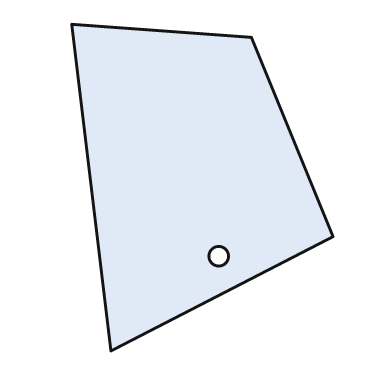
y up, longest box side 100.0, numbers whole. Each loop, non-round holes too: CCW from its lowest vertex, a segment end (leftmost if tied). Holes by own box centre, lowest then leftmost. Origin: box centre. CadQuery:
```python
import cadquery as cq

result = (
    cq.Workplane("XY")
    .moveTo(-28.0, -50.0)
    .lineTo(40.0, -15.0)
    .lineTo(15.0, 46.0)
    .lineTo(-40.0, 50.0)
    .close()
    .moveTo(5.0, -21.0)
    .circle(3.0)
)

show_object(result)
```